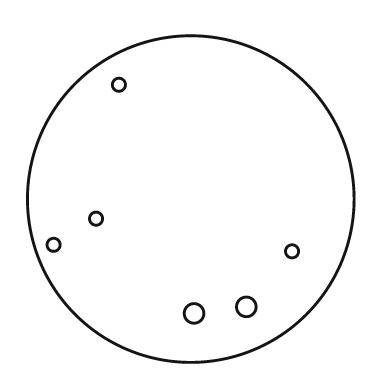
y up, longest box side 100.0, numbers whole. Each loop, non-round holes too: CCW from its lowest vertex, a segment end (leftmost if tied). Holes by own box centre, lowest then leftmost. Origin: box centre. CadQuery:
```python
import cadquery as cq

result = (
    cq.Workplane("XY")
    .moveTo(0.0, 0.0)
    .circle(50.0)
    .moveTo(1.0, -35.0)
    .circle(3.0)
    .moveTo(17.0, -33.0)
    .circle(3.0)
    .moveTo(31.0, -16.0)
    .circle(2.0)
    .moveTo(-42.0, -14.0)
    .circle(2.0)
    .moveTo(-29.0, -6.0)
    .circle(2.0)
    .moveTo(-22.0, 35.0)
    .circle(2.0)
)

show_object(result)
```